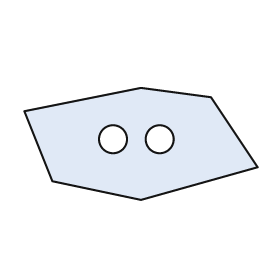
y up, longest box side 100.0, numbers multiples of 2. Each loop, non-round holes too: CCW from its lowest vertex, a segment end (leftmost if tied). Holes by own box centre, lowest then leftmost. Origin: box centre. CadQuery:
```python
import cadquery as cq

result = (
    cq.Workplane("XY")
    .moveTo(0.0, -24.0)
    .lineTo(50.0, -10.0)
    .lineTo(30.0, 20.0)
    .lineTo(0.0, 24.0)
    .lineTo(-50.0, 14.0)
    .lineTo(-38.0, -16.0)
    .close()
    .moveTo(-12.0, 2.0)
    .circle(6.0)
    .moveTo(8.0, 2.0)
    .circle(6.0)
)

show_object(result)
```